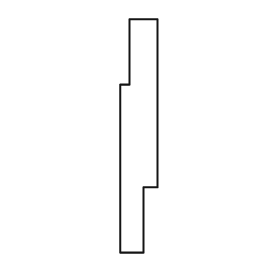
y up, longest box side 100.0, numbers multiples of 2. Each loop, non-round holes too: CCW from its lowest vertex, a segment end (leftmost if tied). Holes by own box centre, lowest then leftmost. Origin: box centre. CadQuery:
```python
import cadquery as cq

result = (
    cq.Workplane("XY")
    .moveTo(-8.0, -50.0)
    .lineTo(2.0, -50.0)
    .lineTo(2.0, -22.0)
    .lineTo(8.0, -22.0)
    .lineTo(8.0, 50.0)
    .lineTo(-4.0, 50.0)
    .lineTo(-4.0, 22.0)
    .lineTo(-8.0, 22.0)
    .close()
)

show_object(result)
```